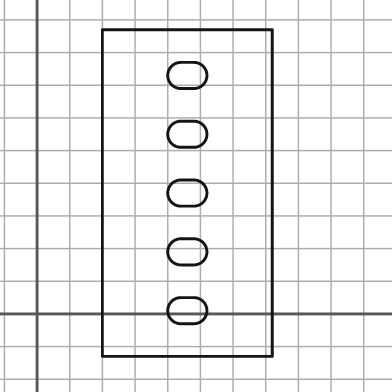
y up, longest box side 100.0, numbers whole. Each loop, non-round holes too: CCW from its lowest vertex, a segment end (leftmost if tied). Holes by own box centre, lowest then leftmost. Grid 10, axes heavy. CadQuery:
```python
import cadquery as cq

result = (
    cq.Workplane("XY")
    .moveTo(20.0, -13.0)
    .lineTo(72.0, -13.0)
    .lineTo(72.0, 87.0)
    .lineTo(20.0, 87.0)
    .close()
    .moveTo(44.0, -3.0)
    .lineTo(48.0, -3.0)
    .threePointArc((52.0, 1.0), (48.0, 5.0))
    .lineTo(44.0, 5.0)
    .threePointArc((40.0, 1.0), (44.0, -3.0))
    .close()
    .moveTo(44.0, 15.0)
    .lineTo(48.0, 15.0)
    .threePointArc((52.0, 19.0), (48.0, 23.0))
    .lineTo(44.0, 23.0)
    .threePointArc((40.0, 19.0), (44.0, 15.0))
    .close()
    .moveTo(44.0, 33.0)
    .lineTo(48.0, 33.0)
    .threePointArc((52.0, 37.0), (48.0, 41.0))
    .lineTo(44.0, 41.0)
    .threePointArc((40.0, 37.0), (44.0, 33.0))
    .close()
    .moveTo(44.0, 51.0)
    .lineTo(48.0, 51.0)
    .threePointArc((52.0, 55.0), (48.0, 59.0))
    .lineTo(44.0, 59.0)
    .threePointArc((40.0, 55.0), (44.0, 51.0))
    .close()
    .moveTo(44.0, 69.0)
    .lineTo(48.0, 69.0)
    .threePointArc((52.0, 73.0), (48.0, 77.0))
    .lineTo(44.0, 77.0)
    .threePointArc((40.0, 73.0), (44.0, 69.0))
    .close()
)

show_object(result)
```